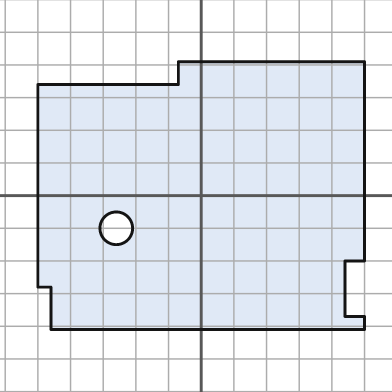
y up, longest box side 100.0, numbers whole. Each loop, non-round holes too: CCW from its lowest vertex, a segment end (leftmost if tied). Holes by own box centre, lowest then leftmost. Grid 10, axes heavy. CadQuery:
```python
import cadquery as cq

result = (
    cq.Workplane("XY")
    .moveTo(-46.0, -41.0)
    .lineTo(50.0, -41.0)
    .lineTo(50.0, -37.0)
    .lineTo(44.0, -37.0)
    .lineTo(44.0, -20.0)
    .lineTo(50.0, -20.0)
    .lineTo(50.0, 41.0)
    .lineTo(-7.0, 41.0)
    .lineTo(-7.0, 34.0)
    .lineTo(-50.0, 34.0)
    .lineTo(-50.0, -28.0)
    .lineTo(-46.0, -28.0)
    .close()
    .moveTo(-26.0, -10.0)
    .circle(5.0)
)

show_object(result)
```